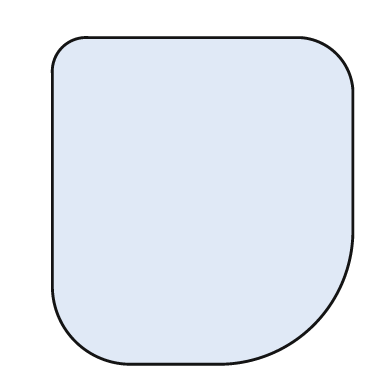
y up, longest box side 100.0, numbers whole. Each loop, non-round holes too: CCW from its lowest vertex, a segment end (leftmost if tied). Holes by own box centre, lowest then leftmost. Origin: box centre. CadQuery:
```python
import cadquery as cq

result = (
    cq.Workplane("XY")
    .moveTo(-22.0, -50.0)
    .lineTo(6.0, -50.0)
    .threePointArc((34.0, -38.0), (46.0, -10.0))
    .lineTo(46.0, 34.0)
    .threePointArc((41.0, 45.0), (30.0, 50.0))
    .lineTo(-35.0, 50.0)
    .threePointArc((-43.0, 47.0), (-46.0, 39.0))
    .lineTo(-46.0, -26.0)
    .threePointArc((-39.0, -43.0), (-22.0, -50.0))
    .close()
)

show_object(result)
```